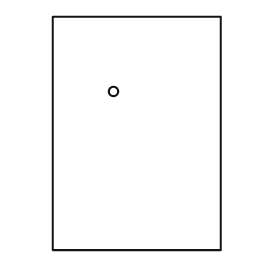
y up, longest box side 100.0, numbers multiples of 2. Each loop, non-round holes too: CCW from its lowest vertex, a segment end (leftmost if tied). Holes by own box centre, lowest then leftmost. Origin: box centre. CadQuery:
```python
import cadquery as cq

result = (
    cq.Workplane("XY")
    .moveTo(-36.0, -50.0)
    .lineTo(36.0, -50.0)
    .lineTo(36.0, 50.0)
    .lineTo(-36.0, 50.0)
    .close()
    .moveTo(-10.0, 18.0)
    .circle(2.0)
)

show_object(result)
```